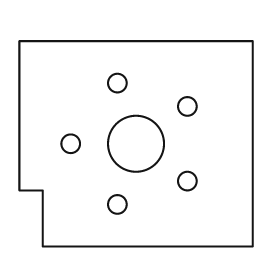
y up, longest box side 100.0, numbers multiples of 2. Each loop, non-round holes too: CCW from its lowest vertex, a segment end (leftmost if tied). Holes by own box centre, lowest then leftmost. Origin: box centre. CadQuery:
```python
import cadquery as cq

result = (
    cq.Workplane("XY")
    .moveTo(-40.0, -44.0)
    .lineTo(50.0, -44.0)
    .lineTo(50.0, 44.0)
    .lineTo(-50.0, 44.0)
    .lineTo(-50.0, -20.0)
    .lineTo(-40.0, -20.0)
    .close()
    .moveTo(-8.0, -26.0)
    .circle(4.0)
    .moveTo(22.0, -16.0)
    .circle(4.0)
    .moveTo(-28.0, 0.0)
    .circle(4.0)
    .moveTo(0.0, 0.0)
    .circle(12.0)
    .moveTo(22.0, 16.0)
    .circle(4.0)
    .moveTo(-8.0, 26.0)
    .circle(4.0)
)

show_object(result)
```